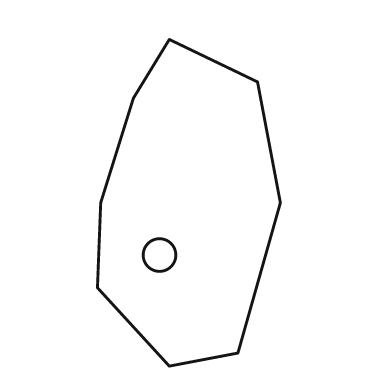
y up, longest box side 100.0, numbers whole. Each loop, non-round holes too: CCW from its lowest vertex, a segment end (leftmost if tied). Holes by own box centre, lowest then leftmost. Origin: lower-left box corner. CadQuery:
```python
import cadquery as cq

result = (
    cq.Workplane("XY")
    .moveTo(22.0, 0.0)
    .lineTo(43.0, 4.0)
    .lineTo(56.0, 50.0)
    .lineTo(49.0, 87.0)
    .lineTo(22.0, 100.0)
    .lineTo(11.0, 82.0)
    .lineTo(1.0, 50.0)
    .lineTo(0.0, 24.0)
    .close()
    .moveTo(19.0, 34.0)
    .circle(5.0)
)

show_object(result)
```